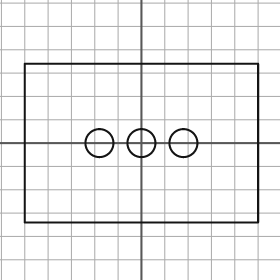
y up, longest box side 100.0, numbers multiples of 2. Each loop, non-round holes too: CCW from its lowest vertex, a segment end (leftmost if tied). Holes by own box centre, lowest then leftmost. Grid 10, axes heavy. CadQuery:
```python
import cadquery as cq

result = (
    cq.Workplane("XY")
    .moveTo(-50.0, -34.0)
    .lineTo(50.0, -34.0)
    .lineTo(50.0, 34.0)
    .lineTo(-50.0, 34.0)
    .close()
    .moveTo(-18.0, 0.0)
    .circle(6.0)
    .moveTo(0.0, 0.0)
    .circle(6.0)
    .moveTo(18.0, 0.0)
    .circle(6.0)
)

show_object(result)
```